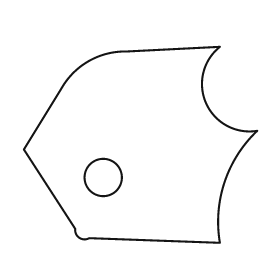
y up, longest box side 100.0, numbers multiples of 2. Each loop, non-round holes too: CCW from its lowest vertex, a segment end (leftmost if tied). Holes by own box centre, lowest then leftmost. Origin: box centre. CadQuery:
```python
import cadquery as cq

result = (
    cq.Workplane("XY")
    .moveTo(34.0, -42.0)
    .threePointArc((36.0, -16.0), (50.0, 6.0))
    .threePointArc((28.0, 18.0), (34.0, 42.0))
    .lineTo(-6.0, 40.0)
    .threePointArc((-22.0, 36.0), (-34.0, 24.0))
    .lineTo(-50.0, -2.0)
    .lineTo(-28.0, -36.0)
    .threePointArc((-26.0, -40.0), (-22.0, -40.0))
    .close()
    .moveTo(-16.0, -14.0)
    .circle(8.0)
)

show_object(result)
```